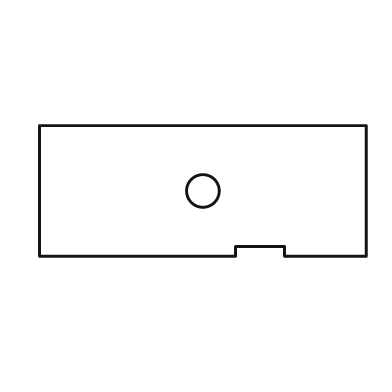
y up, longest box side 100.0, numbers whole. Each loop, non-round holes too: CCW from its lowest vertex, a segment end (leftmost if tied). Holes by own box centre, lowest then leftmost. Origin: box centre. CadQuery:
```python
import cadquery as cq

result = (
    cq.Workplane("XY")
    .moveTo(-50.0, -20.0)
    .lineTo(10.0, -20.0)
    .lineTo(10.0, -17.0)
    .lineTo(25.0, -17.0)
    .lineTo(25.0, -20.0)
    .lineTo(50.0, -20.0)
    .lineTo(50.0, 20.0)
    .lineTo(-50.0, 20.0)
    .close()
    .moveTo(0.0, 0.0)
    .circle(5.0)
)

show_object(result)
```